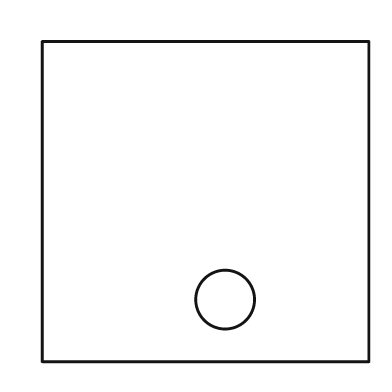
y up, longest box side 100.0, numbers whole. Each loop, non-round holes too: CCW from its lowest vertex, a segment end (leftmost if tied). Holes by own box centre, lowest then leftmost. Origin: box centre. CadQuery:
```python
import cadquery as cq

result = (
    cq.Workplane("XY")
    .moveTo(-50.0, -49.0)
    .lineTo(50.0, -49.0)
    .lineTo(50.0, 49.0)
    .lineTo(-50.0, 49.0)
    .close()
    .moveTo(6.0, -30.0)
    .circle(9.0)
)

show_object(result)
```